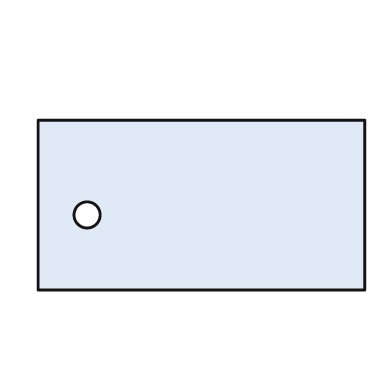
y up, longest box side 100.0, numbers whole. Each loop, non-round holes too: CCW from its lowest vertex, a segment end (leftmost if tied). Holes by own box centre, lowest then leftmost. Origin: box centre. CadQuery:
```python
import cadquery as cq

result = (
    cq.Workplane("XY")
    .moveTo(-50.0, -26.0)
    .lineTo(50.0, -26.0)
    .lineTo(50.0, 26.0)
    .lineTo(-50.0, 26.0)
    .close()
    .moveTo(-35.0, -3.0)
    .circle(4.0)
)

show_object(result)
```